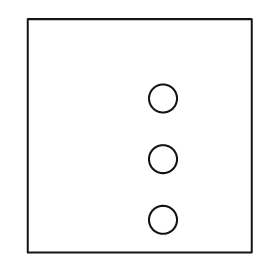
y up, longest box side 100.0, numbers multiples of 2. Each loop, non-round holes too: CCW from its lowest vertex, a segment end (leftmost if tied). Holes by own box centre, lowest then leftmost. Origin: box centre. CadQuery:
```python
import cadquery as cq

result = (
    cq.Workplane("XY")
    .moveTo(-48.0, -50.0)
    .lineTo(48.0, -50.0)
    .lineTo(48.0, 50.0)
    .lineTo(-48.0, 50.0)
    .close()
    .moveTo(10.0, -36.0)
    .circle(6.0)
    .moveTo(10.0, -10.0)
    .circle(6.0)
    .moveTo(10.0, 16.0)
    .circle(6.0)
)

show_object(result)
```